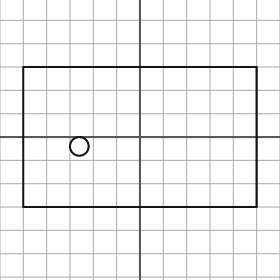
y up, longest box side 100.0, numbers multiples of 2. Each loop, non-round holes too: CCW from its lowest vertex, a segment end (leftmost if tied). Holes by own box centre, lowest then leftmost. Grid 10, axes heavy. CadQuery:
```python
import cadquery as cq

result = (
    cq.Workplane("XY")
    .moveTo(-50.0, -30.0)
    .lineTo(50.0, -30.0)
    .lineTo(50.0, 30.0)
    .lineTo(-50.0, 30.0)
    .close()
    .moveTo(-26.0, -4.0)
    .circle(4.0)
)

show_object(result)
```